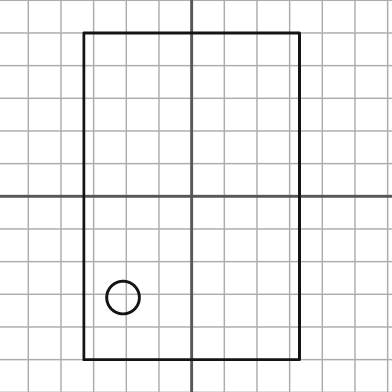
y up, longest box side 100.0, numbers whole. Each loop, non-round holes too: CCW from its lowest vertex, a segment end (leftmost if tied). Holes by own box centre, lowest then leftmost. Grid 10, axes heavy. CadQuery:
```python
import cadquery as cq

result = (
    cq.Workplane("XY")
    .moveTo(-33.0, -50.0)
    .lineTo(33.0, -50.0)
    .lineTo(33.0, 50.0)
    .lineTo(-33.0, 50.0)
    .close()
    .moveTo(-21.0, -31.0)
    .circle(5.0)
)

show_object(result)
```